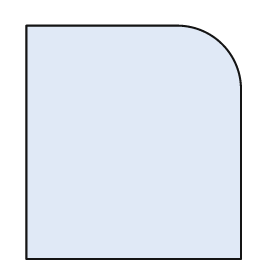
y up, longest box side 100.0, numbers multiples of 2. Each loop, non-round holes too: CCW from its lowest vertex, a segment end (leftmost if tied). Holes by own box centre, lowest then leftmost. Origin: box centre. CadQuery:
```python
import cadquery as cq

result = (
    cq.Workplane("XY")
    .moveTo(-46.0, -50.0)
    .lineTo(46.0, -50.0)
    .lineTo(46.0, 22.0)
    .threePointArc((38.0, 42.0), (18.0, 50.0))
    .lineTo(-46.0, 50.0)
    .close()
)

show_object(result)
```